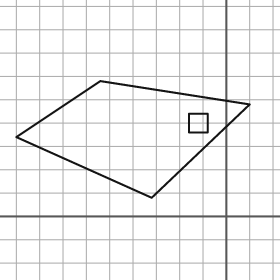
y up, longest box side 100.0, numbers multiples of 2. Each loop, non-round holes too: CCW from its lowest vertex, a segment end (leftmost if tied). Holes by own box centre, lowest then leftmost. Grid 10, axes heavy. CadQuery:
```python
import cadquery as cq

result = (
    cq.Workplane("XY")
    .moveTo(-32.0, 8.0)
    .lineTo(10.0, 48.0)
    .lineTo(-54.0, 58.0)
    .lineTo(-90.0, 34.0)
    .close()
    .moveTo(-16.0, 36.0)
    .lineTo(-8.0, 36.0)
    .lineTo(-8.0, 44.0)
    .lineTo(-16.0, 44.0)
    .close()
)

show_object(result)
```